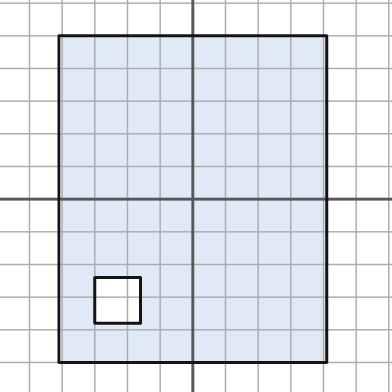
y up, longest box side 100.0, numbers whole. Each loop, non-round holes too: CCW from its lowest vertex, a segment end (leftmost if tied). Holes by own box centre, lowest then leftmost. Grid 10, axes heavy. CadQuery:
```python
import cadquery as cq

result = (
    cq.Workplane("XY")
    .moveTo(-41.0, -50.0)
    .lineTo(41.0, -50.0)
    .lineTo(41.0, 50.0)
    .lineTo(-41.0, 50.0)
    .close()
    .moveTo(-30.0, -38.0)
    .lineTo(-16.0, -38.0)
    .lineTo(-16.0, -24.0)
    .lineTo(-30.0, -24.0)
    .close()
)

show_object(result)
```